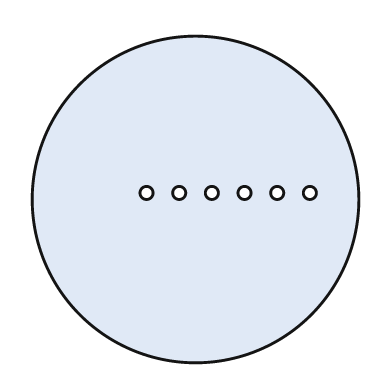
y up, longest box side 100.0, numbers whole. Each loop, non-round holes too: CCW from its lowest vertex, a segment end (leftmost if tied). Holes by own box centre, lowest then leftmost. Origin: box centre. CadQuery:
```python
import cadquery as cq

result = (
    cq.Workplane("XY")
    .moveTo(0.0, 0.0)
    .circle(50.0)
    .moveTo(-15.0, 2.0)
    .circle(2.0)
    .moveTo(-5.0, 2.0)
    .circle(2.0)
    .moveTo(5.0, 2.0)
    .circle(2.0)
    .moveTo(15.0, 2.0)
    .circle(2.0)
    .moveTo(25.0, 2.0)
    .circle(2.0)
    .moveTo(35.0, 2.0)
    .circle(2.0)
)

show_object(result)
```